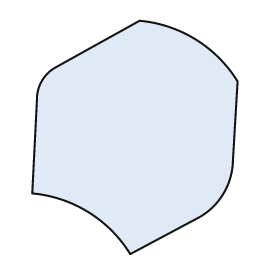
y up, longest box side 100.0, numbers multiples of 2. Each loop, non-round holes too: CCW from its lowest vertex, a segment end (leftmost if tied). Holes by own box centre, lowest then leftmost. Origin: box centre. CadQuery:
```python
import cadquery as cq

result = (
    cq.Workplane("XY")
    .moveTo(-2.0, -50.0)
    .lineTo(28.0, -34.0)
    .threePointArc((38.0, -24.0), (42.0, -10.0))
    .lineTo(44.0, 24.0)
    .threePointArc((26.0, 42.0), (2.0, 50.0))
    .lineTo(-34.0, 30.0)
    .threePointArc((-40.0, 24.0), (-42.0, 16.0))
    .lineTo(-44.0, -24.0)
    .threePointArc((-20.0, -32.0), (-2.0, -50.0))
    .close()
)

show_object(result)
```